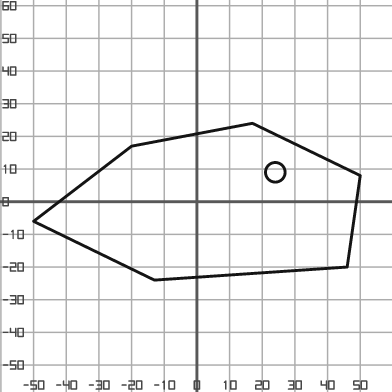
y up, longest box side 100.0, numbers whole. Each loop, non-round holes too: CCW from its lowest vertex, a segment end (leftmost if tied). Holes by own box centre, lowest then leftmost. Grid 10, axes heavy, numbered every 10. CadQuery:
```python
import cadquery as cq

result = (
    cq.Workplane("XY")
    .moveTo(-13.0, -24.0)
    .lineTo(46.0, -20.0)
    .lineTo(50.0, 8.0)
    .lineTo(17.0, 24.0)
    .lineTo(-20.0, 17.0)
    .lineTo(-50.0, -6.0)
    .close()
    .moveTo(24.0, 9.0)
    .circle(3.0)
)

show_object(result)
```